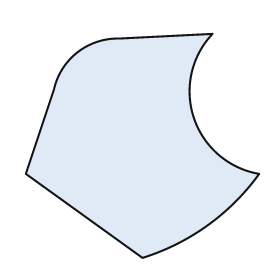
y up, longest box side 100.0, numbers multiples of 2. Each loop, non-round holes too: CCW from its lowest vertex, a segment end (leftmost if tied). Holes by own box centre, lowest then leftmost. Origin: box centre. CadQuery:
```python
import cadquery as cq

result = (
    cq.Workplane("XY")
    .moveTo(0.0, -48.0)
    .threePointArc((28.0, -34.0), (50.0, -12.0))
    .threePointArc((22.0, 12.0), (30.0, 48.0))
    .lineTo(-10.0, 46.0)
    .threePointArc((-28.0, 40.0), (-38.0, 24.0))
    .lineTo(-50.0, -12.0)
    .close()
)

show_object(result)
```